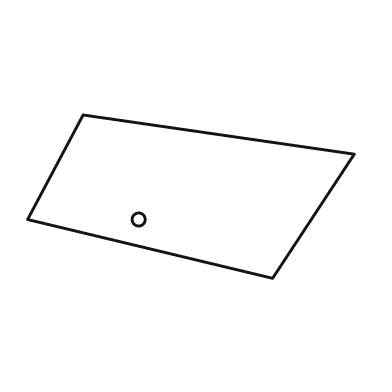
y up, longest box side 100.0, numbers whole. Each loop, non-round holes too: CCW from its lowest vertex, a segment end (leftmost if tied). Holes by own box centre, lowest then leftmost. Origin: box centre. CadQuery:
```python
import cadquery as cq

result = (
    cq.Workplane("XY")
    .moveTo(25.0, -25.0)
    .lineTo(50.0, 13.0)
    .lineTo(-33.0, 25.0)
    .lineTo(-50.0, -7.0)
    .close()
    .moveTo(-16.0, -7.0)
    .circle(2.0)
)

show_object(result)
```